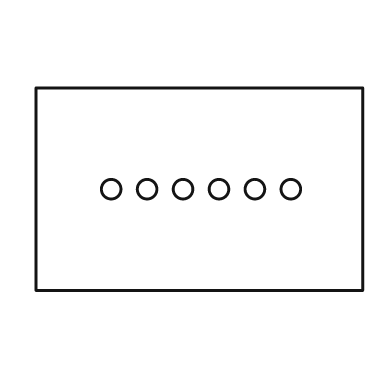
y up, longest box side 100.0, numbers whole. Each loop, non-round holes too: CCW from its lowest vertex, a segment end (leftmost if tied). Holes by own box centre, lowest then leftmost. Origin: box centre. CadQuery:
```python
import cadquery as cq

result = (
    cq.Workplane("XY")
    .moveTo(-50.0, -31.0)
    .lineTo(50.0, -31.0)
    .lineTo(50.0, 31.0)
    .lineTo(-50.0, 31.0)
    .close()
    .moveTo(-27.0, 0.0)
    .circle(3.0)
    .moveTo(-16.0, 0.0)
    .circle(3.0)
    .moveTo(-5.0, 0.0)
    .circle(3.0)
    .moveTo(6.0, 0.0)
    .circle(3.0)
    .moveTo(17.0, 0.0)
    .circle(3.0)
    .moveTo(28.0, 0.0)
    .circle(3.0)
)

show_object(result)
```